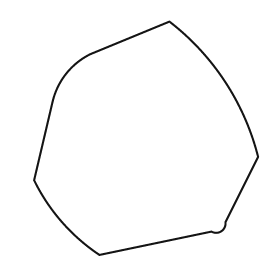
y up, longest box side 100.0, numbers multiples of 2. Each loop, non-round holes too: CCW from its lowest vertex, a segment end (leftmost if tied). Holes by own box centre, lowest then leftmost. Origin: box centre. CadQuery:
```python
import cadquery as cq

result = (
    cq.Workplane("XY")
    .moveTo(-20.0, -50.0)
    .lineTo(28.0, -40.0)
    .threePointArc((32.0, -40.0), (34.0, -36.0))
    .lineTo(48.0, -8.0)
    .threePointArc((34.0, 24.0), (10.0, 50.0))
    .lineTo(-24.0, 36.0)
    .threePointArc((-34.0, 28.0), (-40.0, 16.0))
    .lineTo(-48.0, -18.0)
    .threePointArc((-36.0, -36.0), (-20.0, -50.0))
    .close()
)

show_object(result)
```